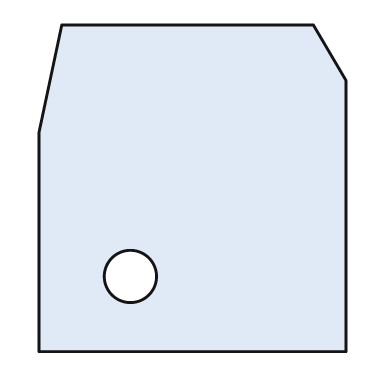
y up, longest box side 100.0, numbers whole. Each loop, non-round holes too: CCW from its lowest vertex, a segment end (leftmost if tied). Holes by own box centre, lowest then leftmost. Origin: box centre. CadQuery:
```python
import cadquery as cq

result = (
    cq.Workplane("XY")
    .moveTo(-47.0, -50.0)
    .lineTo(47.0, -50.0)
    .lineTo(47.0, 33.0)
    .lineTo(37.0, 50.0)
    .lineTo(-40.0, 50.0)
    .lineTo(-47.0, 17.0)
    .close()
    .moveTo(-19.0, -27.0)
    .circle(8.0)
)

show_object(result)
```